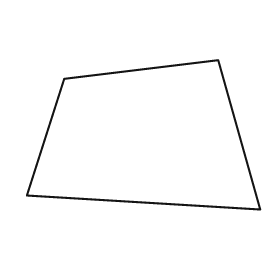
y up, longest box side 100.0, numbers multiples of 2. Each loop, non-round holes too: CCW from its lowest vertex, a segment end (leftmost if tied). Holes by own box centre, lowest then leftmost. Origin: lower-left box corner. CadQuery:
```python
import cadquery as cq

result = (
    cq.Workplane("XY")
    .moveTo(100.0, 0.0)
    .lineTo(82.0, 64.0)
    .lineTo(16.0, 56.0)
    .lineTo(0.0, 6.0)
    .close()
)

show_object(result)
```